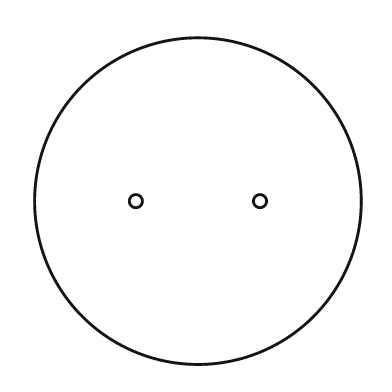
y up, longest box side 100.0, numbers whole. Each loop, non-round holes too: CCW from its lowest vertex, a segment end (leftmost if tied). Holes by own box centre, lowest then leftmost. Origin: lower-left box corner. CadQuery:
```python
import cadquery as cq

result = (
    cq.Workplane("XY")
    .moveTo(50.0, 50.0)
    .circle(50.0)
    .moveTo(31.0, 50.0)
    .circle(2.0)
    .moveTo(69.0, 50.0)
    .circle(2.0)
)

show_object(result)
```